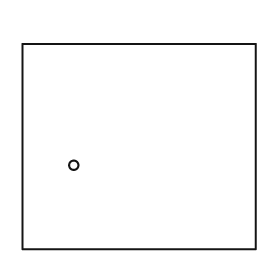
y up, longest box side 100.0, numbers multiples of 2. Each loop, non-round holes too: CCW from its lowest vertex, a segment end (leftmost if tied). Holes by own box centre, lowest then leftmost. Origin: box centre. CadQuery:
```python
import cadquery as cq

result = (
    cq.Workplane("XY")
    .moveTo(-50.0, -44.0)
    .lineTo(50.0, -44.0)
    .lineTo(50.0, 44.0)
    .lineTo(-50.0, 44.0)
    .close()
    .moveTo(-28.0, -8.0)
    .circle(2.0)
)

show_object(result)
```